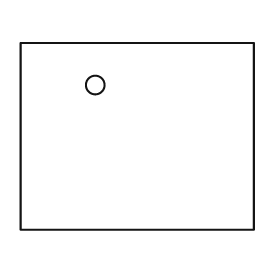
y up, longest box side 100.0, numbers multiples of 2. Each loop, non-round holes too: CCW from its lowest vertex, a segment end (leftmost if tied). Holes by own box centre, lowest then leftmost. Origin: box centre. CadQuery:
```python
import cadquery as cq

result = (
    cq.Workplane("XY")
    .moveTo(-50.0, -40.0)
    .lineTo(50.0, -40.0)
    .lineTo(50.0, 40.0)
    .lineTo(-50.0, 40.0)
    .close()
    .moveTo(-18.0, 22.0)
    .circle(4.0)
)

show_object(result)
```